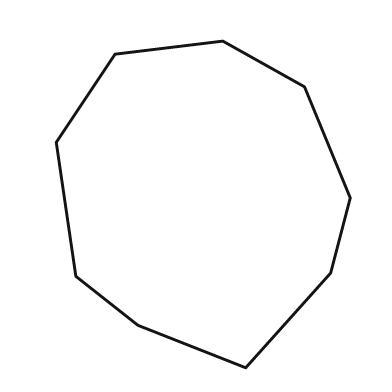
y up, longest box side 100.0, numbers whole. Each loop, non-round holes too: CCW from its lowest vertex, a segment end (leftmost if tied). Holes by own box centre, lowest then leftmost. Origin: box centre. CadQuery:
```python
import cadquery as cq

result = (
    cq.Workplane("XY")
    .moveTo(13.0, -50.0)
    .lineTo(39.0, -21.0)
    .lineTo(45.0, 2.0)
    .lineTo(31.0, 36.0)
    .lineTo(6.0, 50.0)
    .lineTo(-27.0, 46.0)
    .lineTo(-45.0, 19.0)
    .lineTo(-39.0, -22.0)
    .lineTo(-20.0, -37.0)
    .close()
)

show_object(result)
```